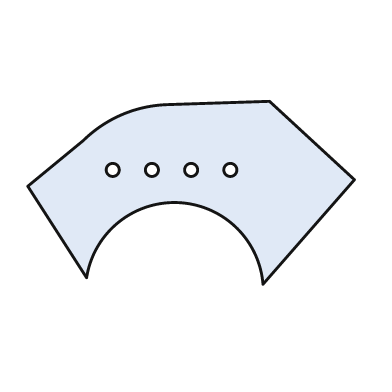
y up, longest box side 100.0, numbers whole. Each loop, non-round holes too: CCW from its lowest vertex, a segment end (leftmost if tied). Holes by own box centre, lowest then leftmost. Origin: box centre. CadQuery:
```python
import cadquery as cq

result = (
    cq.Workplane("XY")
    .moveTo(22.0, -28.0)
    .lineTo(50.0, 4.0)
    .lineTo(24.0, 28.0)
    .lineTo(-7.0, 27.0)
    .threePointArc((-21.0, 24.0), (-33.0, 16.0))
    .lineTo(-50.0, 2.0)
    .lineTo(-32.0, -26.0)
    .threePointArc((-4.0, -3.0), (22.0, -28.0))
    .close()
    .moveTo(-24.0, 7.0)
    .circle(2.0)
    .moveTo(-12.0, 7.0)
    .circle(2.0)
    .moveTo(0.0, 7.0)
    .circle(2.0)
    .moveTo(12.0, 7.0)
    .circle(2.0)
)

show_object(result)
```